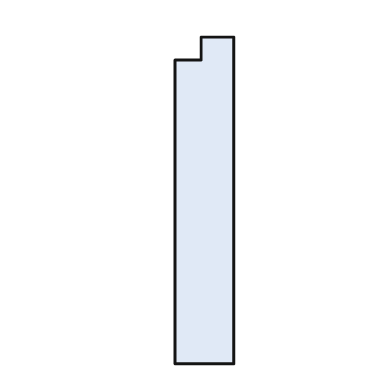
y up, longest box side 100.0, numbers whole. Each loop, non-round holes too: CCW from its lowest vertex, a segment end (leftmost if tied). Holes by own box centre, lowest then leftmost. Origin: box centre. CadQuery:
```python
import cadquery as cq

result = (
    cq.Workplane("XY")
    .moveTo(-9.0, -50.0)
    .lineTo(9.0, -50.0)
    .lineTo(9.0, 50.0)
    .lineTo(-1.0, 50.0)
    .lineTo(-1.0, 43.0)
    .lineTo(-9.0, 43.0)
    .close()
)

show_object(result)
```